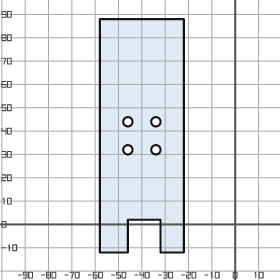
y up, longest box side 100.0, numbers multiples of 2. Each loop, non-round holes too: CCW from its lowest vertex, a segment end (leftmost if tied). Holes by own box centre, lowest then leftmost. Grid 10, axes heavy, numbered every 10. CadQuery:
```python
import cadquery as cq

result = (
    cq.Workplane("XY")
    .moveTo(-58.0, -12.0)
    .lineTo(-46.0, -12.0)
    .lineTo(-46.0, 2.0)
    .lineTo(-32.0, 2.0)
    .lineTo(-32.0, -12.0)
    .lineTo(-22.0, -12.0)
    .lineTo(-22.0, 88.0)
    .lineTo(-58.0, 88.0)
    .close()
    .moveTo(-46.0, 32.0)
    .circle(2.0)
    .moveTo(-34.0, 32.0)
    .circle(2.0)
    .moveTo(-46.0, 44.0)
    .circle(2.0)
    .moveTo(-34.0, 44.0)
    .circle(2.0)
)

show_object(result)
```